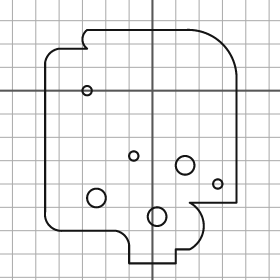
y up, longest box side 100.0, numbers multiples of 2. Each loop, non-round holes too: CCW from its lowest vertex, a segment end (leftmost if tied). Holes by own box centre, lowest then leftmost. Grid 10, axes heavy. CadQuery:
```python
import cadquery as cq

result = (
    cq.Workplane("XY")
    .moveTo(-10.0, -74.0)
    .lineTo(10.0, -74.0)
    .lineTo(10.0, -68.0)
    .lineTo(16.0, -68.0)
    .threePointArc((22.0, -58.0), (16.0, -48.0))
    .lineTo(36.0, -48.0)
    .lineTo(36.0, 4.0)
    .threePointArc((30.0, 20.0), (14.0, 26.0))
    .lineTo(-28.0, 26.0)
    .threePointArc((-30.0, 22.0), (-28.0, 18.0))
    .lineTo(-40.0, 18.0)
    .threePointArc((-44.0, 16.0), (-46.0, 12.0))
    .lineTo(-46.0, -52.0)
    .threePointArc((-44.0, -58.0), (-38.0, -60.0))
    .lineTo(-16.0, -60.0)
    .threePointArc((-12.0, -62.0), (-10.0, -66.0))
    .close()
    .moveTo(2.0, -54.0)
    .circle(4.0)
    .moveTo(-24.0, -46.0)
    .circle(4.0)
    .moveTo(28.0, -40.0)
    .circle(2.0)
    .moveTo(14.0, -32.0)
    .circle(4.0)
    .moveTo(-8.0, -28.0)
    .circle(2.0)
    .moveTo(-28.0, 0.0)
    .circle(2.0)
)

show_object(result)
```